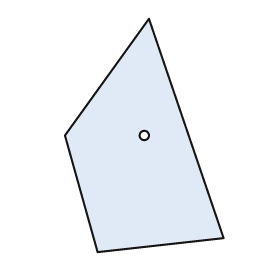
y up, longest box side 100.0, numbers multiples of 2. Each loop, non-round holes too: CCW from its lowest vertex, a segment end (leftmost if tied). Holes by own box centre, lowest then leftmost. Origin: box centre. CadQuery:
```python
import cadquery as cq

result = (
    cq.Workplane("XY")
    .moveTo(-20.0, -50.0)
    .lineTo(34.0, -44.0)
    .lineTo(2.0, 50.0)
    .lineTo(-34.0, 0.0)
    .close()
    .moveTo(0.0, 0.0)
    .circle(2.0)
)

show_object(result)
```